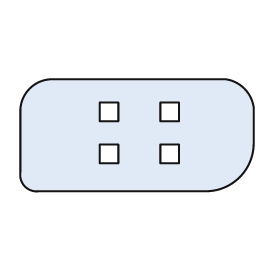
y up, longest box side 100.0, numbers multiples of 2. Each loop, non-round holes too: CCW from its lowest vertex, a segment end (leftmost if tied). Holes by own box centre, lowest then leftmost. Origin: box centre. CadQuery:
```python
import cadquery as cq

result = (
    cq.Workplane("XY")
    .moveTo(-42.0, -24.0)
    .lineTo(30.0, -24.0)
    .threePointArc((44.0, -18.0), (50.0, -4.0))
    .lineTo(50.0, 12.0)
    .threePointArc((46.0, 20.0), (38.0, 24.0))
    .lineTo(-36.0, 24.0)
    .threePointArc((-46.0, 20.0), (-50.0, 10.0))
    .lineTo(-50.0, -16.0)
    .threePointArc((-48.0, -22.0), (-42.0, -24.0))
    .close()
    .moveTo(-16.0, -12.0)
    .lineTo(-8.0, -12.0)
    .lineTo(-8.0, -4.0)
    .lineTo(-16.0, -4.0)
    .close()
    .moveTo(10.0, -12.0)
    .lineTo(18.0, -12.0)
    .lineTo(18.0, -4.0)
    .lineTo(10.0, -4.0)
    .close()
    .moveTo(-16.0, 6.0)
    .lineTo(-8.0, 6.0)
    .lineTo(-8.0, 14.0)
    .lineTo(-16.0, 14.0)
    .close()
    .moveTo(10.0, 6.0)
    .lineTo(18.0, 6.0)
    .lineTo(18.0, 14.0)
    .lineTo(10.0, 14.0)
    .close()
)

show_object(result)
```